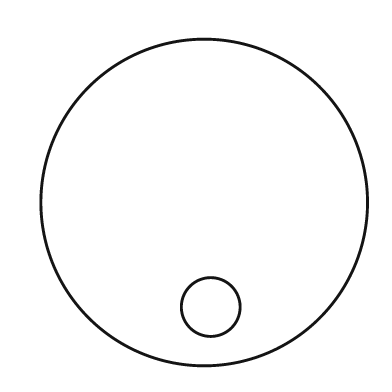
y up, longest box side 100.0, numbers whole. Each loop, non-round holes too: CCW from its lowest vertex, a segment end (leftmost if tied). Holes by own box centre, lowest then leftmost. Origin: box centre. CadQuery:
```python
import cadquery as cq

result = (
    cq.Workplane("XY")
    .moveTo(0.0, 0.0)
    .circle(50.0)
    .moveTo(2.0, -32.0)
    .circle(9.0)
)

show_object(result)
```